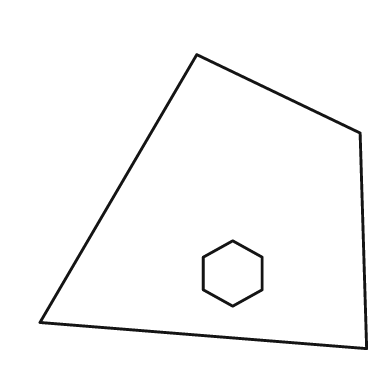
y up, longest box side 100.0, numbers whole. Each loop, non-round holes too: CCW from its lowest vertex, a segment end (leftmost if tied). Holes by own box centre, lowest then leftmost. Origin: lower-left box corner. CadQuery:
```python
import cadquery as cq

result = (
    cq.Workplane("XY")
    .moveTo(100.0, 0.0)
    .lineTo(98.0, 66.0)
    .lineTo(48.0, 90.0)
    .lineTo(0.0, 8.0)
    .close()
    .moveTo(59.0, 13.0)
    .lineTo(68.0, 18.0)
    .lineTo(68.0, 28.0)
    .lineTo(59.0, 33.0)
    .lineTo(50.0, 28.0)
    .lineTo(50.0, 18.0)
    .close()
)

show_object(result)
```